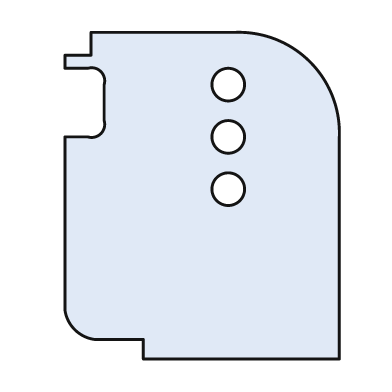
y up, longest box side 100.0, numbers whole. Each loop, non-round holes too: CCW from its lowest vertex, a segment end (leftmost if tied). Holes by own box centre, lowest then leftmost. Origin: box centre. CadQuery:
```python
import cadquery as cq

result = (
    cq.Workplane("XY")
    .moveTo(-18.0, -50.0)
    .lineTo(42.0, -50.0)
    .lineTo(42.0, 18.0)
    .threePointArc((33.0, 41.0), (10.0, 50.0))
    .lineTo(-34.0, 50.0)
    .lineTo(-34.0, 43.0)
    .lineTo(-42.0, 43.0)
    .lineTo(-42.0, 39.0)
    .lineTo(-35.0, 39.0)
    .threePointArc((-31.0, 38.0), (-30.0, 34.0))
    .lineTo(-30.0, 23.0)
    .threePointArc((-31.0, 19.0), (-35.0, 18.0))
    .lineTo(-42.0, 18.0)
    .lineTo(-42.0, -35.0)
    .threePointArc((-39.0, -41.0), (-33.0, -44.0))
    .lineTo(-18.0, -44.0)
    .close()
    .moveTo(8.0, 2.0)
    .circle(5.0)
    .moveTo(8.0, 18.0)
    .circle(5.0)
    .moveTo(8.0, 34.0)
    .circle(5.0)
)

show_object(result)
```